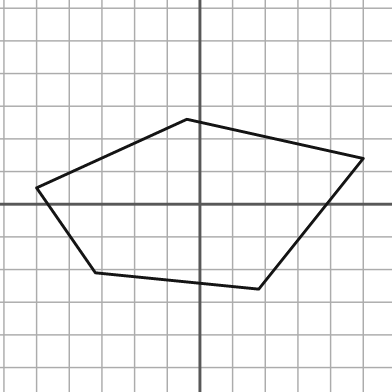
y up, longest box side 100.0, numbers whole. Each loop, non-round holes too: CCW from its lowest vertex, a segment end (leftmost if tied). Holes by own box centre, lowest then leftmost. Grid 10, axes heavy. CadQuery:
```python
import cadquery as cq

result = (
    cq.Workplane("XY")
    .moveTo(18.0, -26.0)
    .lineTo(50.0, 14.0)
    .lineTo(-4.0, 26.0)
    .lineTo(-50.0, 5.0)
    .lineTo(-32.0, -21.0)
    .close()
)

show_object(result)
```